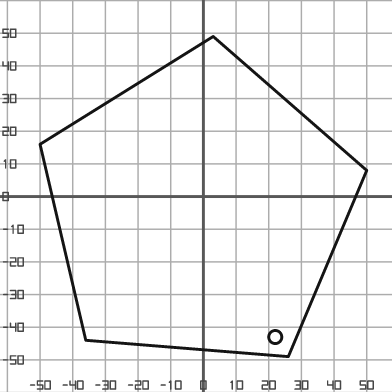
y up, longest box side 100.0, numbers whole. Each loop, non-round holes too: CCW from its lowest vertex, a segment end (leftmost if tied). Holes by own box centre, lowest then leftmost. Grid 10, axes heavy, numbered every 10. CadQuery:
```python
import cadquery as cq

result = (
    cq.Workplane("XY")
    .moveTo(26.0, -49.0)
    .lineTo(50.0, 8.0)
    .lineTo(3.0, 49.0)
    .lineTo(-50.0, 16.0)
    .lineTo(-36.0, -44.0)
    .close()
    .moveTo(22.0, -43.0)
    .circle(2.0)
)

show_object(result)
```